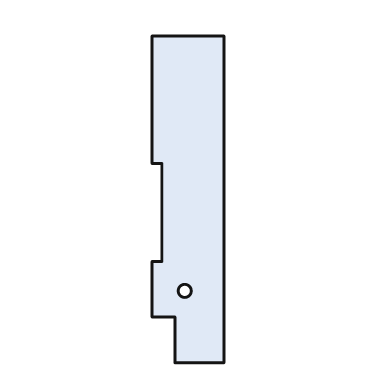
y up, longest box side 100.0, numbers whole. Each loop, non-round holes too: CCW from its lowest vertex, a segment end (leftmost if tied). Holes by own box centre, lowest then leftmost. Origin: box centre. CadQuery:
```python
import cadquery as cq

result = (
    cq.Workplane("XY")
    .moveTo(-4.0, -50.0)
    .lineTo(11.0, -50.0)
    .lineTo(11.0, 50.0)
    .lineTo(-11.0, 50.0)
    .lineTo(-11.0, 11.0)
    .lineTo(-8.0, 11.0)
    .lineTo(-8.0, -19.0)
    .lineTo(-11.0, -19.0)
    .lineTo(-11.0, -36.0)
    .lineTo(-4.0, -36.0)
    .close()
    .moveTo(-1.0, -28.0)
    .circle(2.0)
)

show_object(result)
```